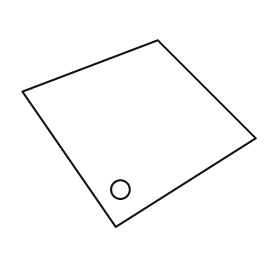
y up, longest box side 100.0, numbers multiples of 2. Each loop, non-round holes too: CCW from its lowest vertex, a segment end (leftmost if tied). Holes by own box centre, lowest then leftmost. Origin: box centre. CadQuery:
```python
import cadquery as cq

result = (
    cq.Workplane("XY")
    .moveTo(-10.0, -40.0)
    .lineTo(50.0, -2.0)
    .lineTo(8.0, 40.0)
    .lineTo(-50.0, 18.0)
    .close()
    .moveTo(-8.0, -24.0)
    .circle(4.0)
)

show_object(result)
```